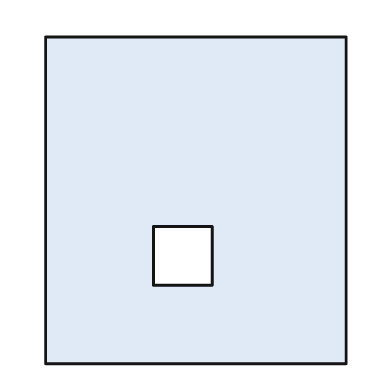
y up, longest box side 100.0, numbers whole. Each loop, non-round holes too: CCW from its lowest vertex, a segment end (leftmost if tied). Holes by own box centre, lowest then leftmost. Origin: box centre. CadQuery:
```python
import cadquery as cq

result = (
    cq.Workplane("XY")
    .moveTo(-46.0, -50.0)
    .lineTo(46.0, -50.0)
    .lineTo(46.0, 50.0)
    .lineTo(-46.0, 50.0)
    .close()
    .moveTo(-13.0, -26.0)
    .lineTo(5.0, -26.0)
    .lineTo(5.0, -8.0)
    .lineTo(-13.0, -8.0)
    .close()
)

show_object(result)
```